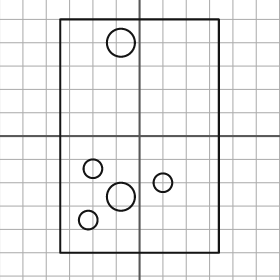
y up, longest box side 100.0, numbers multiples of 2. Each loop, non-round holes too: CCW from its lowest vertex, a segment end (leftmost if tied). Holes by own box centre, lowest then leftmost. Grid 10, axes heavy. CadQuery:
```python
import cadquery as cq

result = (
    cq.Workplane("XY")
    .moveTo(-34.0, -50.0)
    .lineTo(34.0, -50.0)
    .lineTo(34.0, 50.0)
    .lineTo(-34.0, 50.0)
    .close()
    .moveTo(-22.0, -36.0)
    .circle(4.0)
    .moveTo(-8.0, -26.0)
    .circle(6.0)
    .moveTo(10.0, -20.0)
    .circle(4.0)
    .moveTo(-20.0, -14.0)
    .circle(4.0)
    .moveTo(-8.0, 40.0)
    .circle(6.0)
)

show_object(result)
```